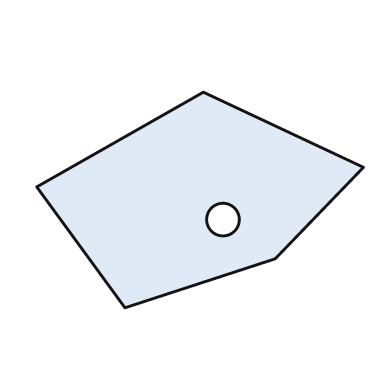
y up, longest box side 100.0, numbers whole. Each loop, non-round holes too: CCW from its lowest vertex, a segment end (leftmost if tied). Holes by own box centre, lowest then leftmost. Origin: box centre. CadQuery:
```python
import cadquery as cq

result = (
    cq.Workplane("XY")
    .moveTo(-23.0, -33.0)
    .lineTo(23.0, -18.0)
    .lineTo(50.0, 10.0)
    .lineTo(1.0, 33.0)
    .lineTo(-50.0, 4.0)
    .close()
    .moveTo(7.0, -6.0)
    .circle(5.0)
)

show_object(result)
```